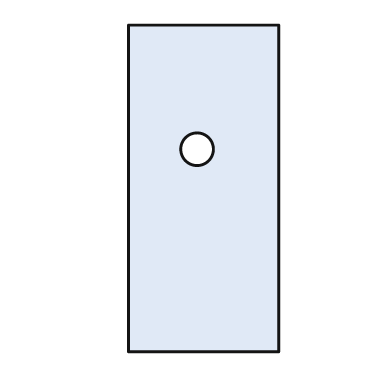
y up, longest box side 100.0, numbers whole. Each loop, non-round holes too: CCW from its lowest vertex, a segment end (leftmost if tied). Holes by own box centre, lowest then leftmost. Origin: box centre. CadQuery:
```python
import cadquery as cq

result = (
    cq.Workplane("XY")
    .moveTo(-23.0, -50.0)
    .lineTo(23.0, -50.0)
    .lineTo(23.0, 50.0)
    .lineTo(-23.0, 50.0)
    .close()
    .moveTo(-2.0, 12.0)
    .circle(5.0)
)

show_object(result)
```